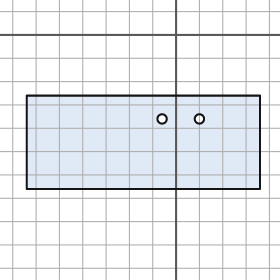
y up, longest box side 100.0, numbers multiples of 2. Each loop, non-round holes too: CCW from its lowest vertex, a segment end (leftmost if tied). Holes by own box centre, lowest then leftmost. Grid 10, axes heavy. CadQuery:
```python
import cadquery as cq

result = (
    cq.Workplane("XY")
    .moveTo(-64.0, -66.0)
    .lineTo(36.0, -66.0)
    .lineTo(36.0, -26.0)
    .lineTo(-64.0, -26.0)
    .close()
    .moveTo(-6.0, -36.0)
    .circle(2.0)
    .moveTo(10.0, -36.0)
    .circle(2.0)
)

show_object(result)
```